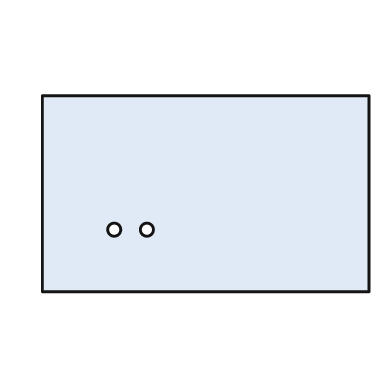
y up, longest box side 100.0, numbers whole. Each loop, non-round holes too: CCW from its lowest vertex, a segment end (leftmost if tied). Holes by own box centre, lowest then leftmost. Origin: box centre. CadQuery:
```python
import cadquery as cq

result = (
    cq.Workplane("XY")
    .moveTo(-50.0, -30.0)
    .lineTo(50.0, -30.0)
    .lineTo(50.0, 30.0)
    .lineTo(-50.0, 30.0)
    .close()
    .moveTo(-28.0, -11.0)
    .circle(2.0)
    .moveTo(-18.0, -11.0)
    .circle(2.0)
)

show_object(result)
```